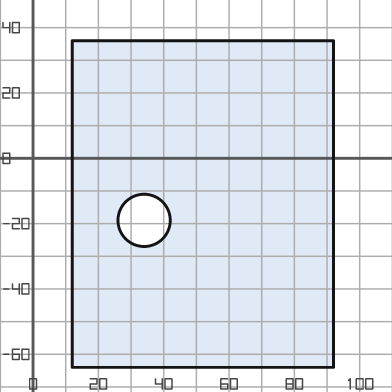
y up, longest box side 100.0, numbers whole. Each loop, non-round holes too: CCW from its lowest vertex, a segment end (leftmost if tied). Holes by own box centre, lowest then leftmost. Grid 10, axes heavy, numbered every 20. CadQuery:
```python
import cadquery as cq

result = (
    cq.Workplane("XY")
    .moveTo(12.0, -64.0)
    .lineTo(92.0, -64.0)
    .lineTo(92.0, 36.0)
    .lineTo(12.0, 36.0)
    .close()
    .moveTo(34.0, -19.0)
    .circle(8.0)
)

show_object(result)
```